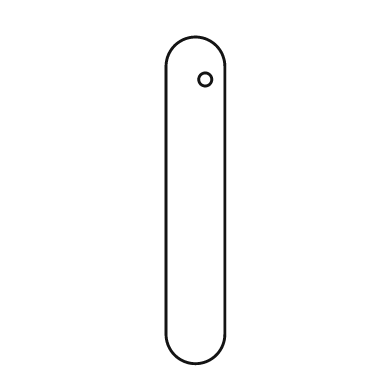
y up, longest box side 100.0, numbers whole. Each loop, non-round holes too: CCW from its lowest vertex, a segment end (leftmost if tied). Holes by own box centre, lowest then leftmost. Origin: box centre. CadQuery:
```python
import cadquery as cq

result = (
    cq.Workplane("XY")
    .moveTo(-9.0, -41.0)
    .threePointArc((0.0, -50.0), (9.0, -41.0))
    .lineTo(9.0, 41.0)
    .threePointArc((0.0, 50.0), (-9.0, 41.0))
    .close()
    .moveTo(3.0, 37.0)
    .circle(2.0)
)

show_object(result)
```